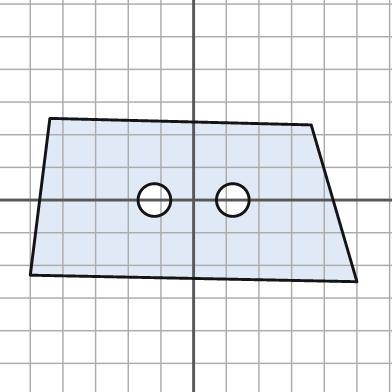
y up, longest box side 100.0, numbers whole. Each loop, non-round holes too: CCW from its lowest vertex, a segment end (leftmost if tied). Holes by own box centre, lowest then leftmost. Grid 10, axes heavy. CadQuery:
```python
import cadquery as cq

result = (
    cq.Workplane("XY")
    .moveTo(50.0, -25.0)
    .lineTo(36.0, 23.0)
    .lineTo(-44.0, 25.0)
    .lineTo(-50.0, -23.0)
    .close()
    .moveTo(-12.0, 0.0)
    .circle(5.0)
    .moveTo(12.0, 0.0)
    .circle(5.0)
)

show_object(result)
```